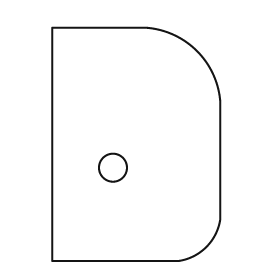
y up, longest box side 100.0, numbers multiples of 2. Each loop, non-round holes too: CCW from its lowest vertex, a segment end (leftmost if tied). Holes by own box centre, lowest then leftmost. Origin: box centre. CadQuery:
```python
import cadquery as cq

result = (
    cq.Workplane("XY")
    .moveTo(-36.0, -50.0)
    .lineTo(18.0, -50.0)
    .threePointArc((30.0, -44.0), (36.0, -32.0))
    .lineTo(36.0, 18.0)
    .threePointArc((26.0, 40.0), (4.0, 50.0))
    .lineTo(-36.0, 50.0)
    .close()
    .moveTo(-10.0, -10.0)
    .circle(6.0)
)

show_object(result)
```